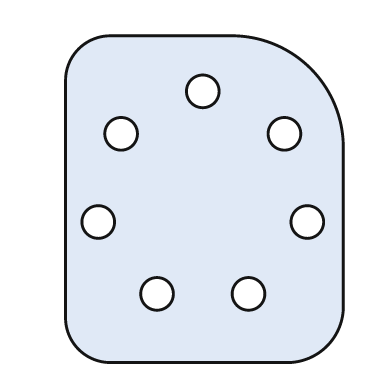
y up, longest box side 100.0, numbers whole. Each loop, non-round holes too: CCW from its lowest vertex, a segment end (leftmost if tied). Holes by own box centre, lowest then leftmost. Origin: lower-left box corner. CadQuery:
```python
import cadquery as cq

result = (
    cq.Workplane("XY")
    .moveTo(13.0, 0.0)
    .lineTo(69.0, 0.0)
    .threePointArc((80.0, 5.0), (85.0, 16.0))
    .lineTo(85.0, 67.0)
    .threePointArc((75.0, 90.0), (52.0, 100.0))
    .lineTo(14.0, 100.0)
    .threePointArc((4.0, 96.0), (0.0, 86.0))
    .lineTo(0.0, 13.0)
    .threePointArc((4.0, 4.0), (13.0, 0.0))
    .close()
    .moveTo(28.0, 21.0)
    .circle(5.0)
    .moveTo(56.0, 21.0)
    .circle(5.0)
    .moveTo(10.0, 43.0)
    .circle(5.0)
    .moveTo(74.0, 43.0)
    .circle(5.0)
    .moveTo(17.0, 70.0)
    .circle(5.0)
    .moveTo(67.0, 70.0)
    .circle(5.0)
    .moveTo(42.0, 83.0)
    .circle(5.0)
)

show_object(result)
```